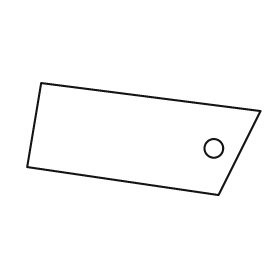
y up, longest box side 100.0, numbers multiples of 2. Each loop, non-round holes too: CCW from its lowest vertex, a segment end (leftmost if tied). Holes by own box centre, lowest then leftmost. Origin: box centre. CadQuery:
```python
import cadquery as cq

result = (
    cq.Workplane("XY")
    .moveTo(32.0, -24.0)
    .lineTo(50.0, 12.0)
    .lineTo(-44.0, 24.0)
    .lineTo(-50.0, -12.0)
    .close()
    .moveTo(30.0, -4.0)
    .circle(4.0)
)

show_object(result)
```